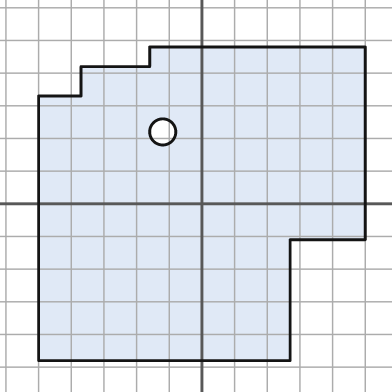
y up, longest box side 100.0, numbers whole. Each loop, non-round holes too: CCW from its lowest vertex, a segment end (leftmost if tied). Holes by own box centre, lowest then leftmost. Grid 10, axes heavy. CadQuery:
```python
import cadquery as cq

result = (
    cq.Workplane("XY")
    .moveTo(-50.0, -48.0)
    .lineTo(27.0, -48.0)
    .lineTo(27.0, -11.0)
    .lineTo(50.0, -11.0)
    .lineTo(50.0, 48.0)
    .lineTo(-16.0, 48.0)
    .lineTo(-16.0, 42.0)
    .lineTo(-37.0, 42.0)
    .lineTo(-37.0, 33.0)
    .lineTo(-50.0, 33.0)
    .close()
    .moveTo(-12.0, 22.0)
    .circle(4.0)
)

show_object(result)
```